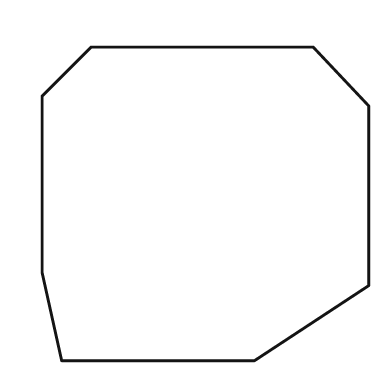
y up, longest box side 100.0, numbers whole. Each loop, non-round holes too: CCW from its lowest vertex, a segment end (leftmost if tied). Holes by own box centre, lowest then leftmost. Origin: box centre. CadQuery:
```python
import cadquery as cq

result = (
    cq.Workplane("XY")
    .moveTo(-44.0, -48.0)
    .lineTo(15.0, -48.0)
    .lineTo(50.0, -25.0)
    .lineTo(50.0, 30.0)
    .lineTo(33.0, 48.0)
    .lineTo(-35.0, 48.0)
    .lineTo(-50.0, 33.0)
    .lineTo(-50.0, -21.0)
    .close()
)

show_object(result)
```